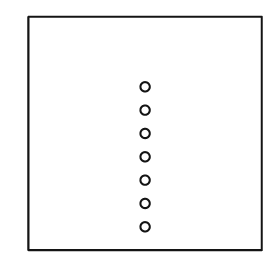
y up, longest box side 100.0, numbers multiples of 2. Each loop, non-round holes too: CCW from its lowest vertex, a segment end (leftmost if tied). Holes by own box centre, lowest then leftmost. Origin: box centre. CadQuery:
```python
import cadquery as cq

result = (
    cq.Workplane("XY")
    .moveTo(-50.0, -50.0)
    .lineTo(50.0, -50.0)
    .lineTo(50.0, 50.0)
    .lineTo(-50.0, 50.0)
    .close()
    .moveTo(0.0, -40.0)
    .circle(2.0)
    .moveTo(0.0, -30.0)
    .circle(2.0)
    .moveTo(0.0, -20.0)
    .circle(2.0)
    .moveTo(0.0, -10.0)
    .circle(2.0)
    .moveTo(0.0, 0.0)
    .circle(2.0)
    .moveTo(0.0, 10.0)
    .circle(2.0)
    .moveTo(0.0, 20.0)
    .circle(2.0)
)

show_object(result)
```